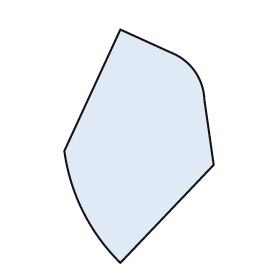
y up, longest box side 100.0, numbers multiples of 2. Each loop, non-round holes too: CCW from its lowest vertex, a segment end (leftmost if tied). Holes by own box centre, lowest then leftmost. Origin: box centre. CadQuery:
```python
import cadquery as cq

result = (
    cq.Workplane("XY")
    .moveTo(-8.0, -50.0)
    .lineTo(32.0, -8.0)
    .lineTo(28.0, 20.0)
    .threePointArc((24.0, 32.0), (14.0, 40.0))
    .lineTo(-8.0, 50.0)
    .lineTo(-32.0, -2.0)
    .threePointArc((-24.0, -28.0), (-8.0, -50.0))
    .close()
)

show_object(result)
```